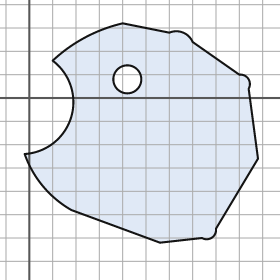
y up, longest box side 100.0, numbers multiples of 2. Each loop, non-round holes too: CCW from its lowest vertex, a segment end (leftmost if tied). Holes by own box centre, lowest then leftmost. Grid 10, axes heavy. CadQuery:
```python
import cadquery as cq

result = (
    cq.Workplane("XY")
    .moveTo(56.0, -62.0)
    .lineTo(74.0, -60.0)
    .threePointArc((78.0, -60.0), (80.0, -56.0))
    .lineTo(98.0, -26.0)
    .lineTo(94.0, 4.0)
    .threePointArc((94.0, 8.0), (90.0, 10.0))
    .lineTo(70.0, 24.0)
    .threePointArc((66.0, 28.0), (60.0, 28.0))
    .lineTo(40.0, 32.0)
    .threePointArc((24.0, 26.0), (10.0, 16.0))
    .threePointArc((18.0, -8.0), (-2.0, -24.0))
    .threePointArc((6.0, -38.0), (18.0, -48.0))
    .close()
    .moveTo(42.0, 8.0)
    .circle(6.0)
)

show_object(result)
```